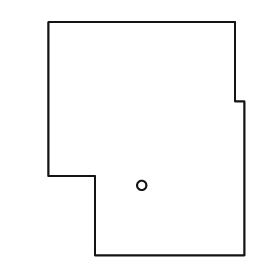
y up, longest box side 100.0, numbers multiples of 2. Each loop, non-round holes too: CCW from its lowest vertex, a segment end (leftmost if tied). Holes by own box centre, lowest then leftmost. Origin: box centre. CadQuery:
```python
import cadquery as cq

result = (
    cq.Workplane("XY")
    .moveTo(-22.0, -50.0)
    .lineTo(42.0, -50.0)
    .lineTo(42.0, 16.0)
    .lineTo(38.0, 16.0)
    .lineTo(38.0, 50.0)
    .lineTo(-42.0, 50.0)
    .lineTo(-42.0, -16.0)
    .lineTo(-22.0, -16.0)
    .close()
    .moveTo(-2.0, -20.0)
    .circle(2.0)
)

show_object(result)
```